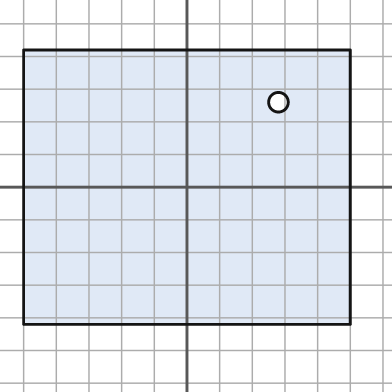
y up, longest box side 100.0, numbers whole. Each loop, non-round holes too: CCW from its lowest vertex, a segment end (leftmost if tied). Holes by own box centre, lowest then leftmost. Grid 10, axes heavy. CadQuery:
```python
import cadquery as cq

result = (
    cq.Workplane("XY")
    .moveTo(-50.0, -42.0)
    .lineTo(50.0, -42.0)
    .lineTo(50.0, 42.0)
    .lineTo(-50.0, 42.0)
    .close()
    .moveTo(28.0, 26.0)
    .circle(3.0)
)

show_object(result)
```